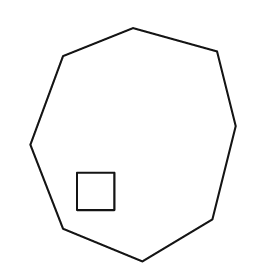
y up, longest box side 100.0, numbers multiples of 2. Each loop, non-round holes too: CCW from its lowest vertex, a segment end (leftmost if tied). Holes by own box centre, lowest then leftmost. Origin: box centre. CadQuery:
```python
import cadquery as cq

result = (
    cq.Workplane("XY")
    .moveTo(4.0, -50.0)
    .lineTo(34.0, -32.0)
    .lineTo(44.0, 8.0)
    .lineTo(36.0, 40.0)
    .lineTo(0.0, 50.0)
    .lineTo(-30.0, 38.0)
    .lineTo(-44.0, 0.0)
    .lineTo(-30.0, -36.0)
    .close()
    .moveTo(-24.0, -28.0)
    .lineTo(-8.0, -28.0)
    .lineTo(-8.0, -12.0)
    .lineTo(-24.0, -12.0)
    .close()
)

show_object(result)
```